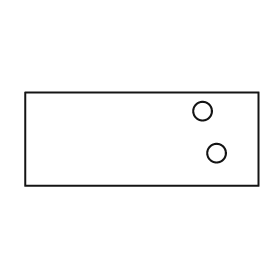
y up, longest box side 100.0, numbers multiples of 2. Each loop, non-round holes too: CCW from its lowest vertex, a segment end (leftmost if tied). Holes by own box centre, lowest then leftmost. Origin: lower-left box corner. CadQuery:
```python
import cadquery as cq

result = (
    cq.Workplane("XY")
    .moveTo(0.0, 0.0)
    .lineTo(100.0, 0.0)
    .lineTo(100.0, 40.0)
    .lineTo(0.0, 40.0)
    .close()
    .moveTo(82.0, 14.0)
    .circle(4.0)
    .moveTo(76.0, 32.0)
    .circle(4.0)
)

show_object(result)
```